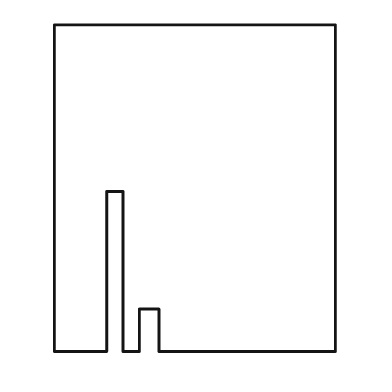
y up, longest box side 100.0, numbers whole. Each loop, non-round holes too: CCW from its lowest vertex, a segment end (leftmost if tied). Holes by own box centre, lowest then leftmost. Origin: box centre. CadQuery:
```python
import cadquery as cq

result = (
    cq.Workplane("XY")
    .moveTo(-43.0, -50.0)
    .lineTo(-27.0, -50.0)
    .lineTo(-27.0, -1.0)
    .lineTo(-22.0, -1.0)
    .lineTo(-22.0, -50.0)
    .lineTo(-17.0, -50.0)
    .lineTo(-17.0, -37.0)
    .lineTo(-11.0, -37.0)
    .lineTo(-11.0, -50.0)
    .lineTo(43.0, -50.0)
    .lineTo(43.0, 50.0)
    .lineTo(-43.0, 50.0)
    .close()
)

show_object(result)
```